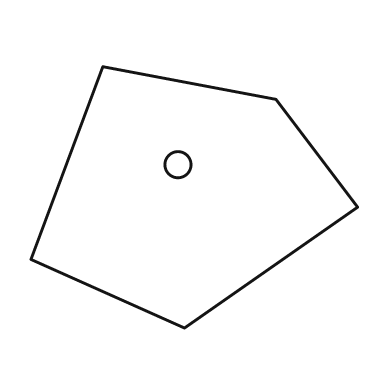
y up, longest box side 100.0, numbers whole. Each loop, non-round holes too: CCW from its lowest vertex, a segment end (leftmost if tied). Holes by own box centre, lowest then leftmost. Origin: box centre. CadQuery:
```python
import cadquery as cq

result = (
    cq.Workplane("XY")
    .moveTo(-3.0, -40.0)
    .lineTo(50.0, -3.0)
    .lineTo(25.0, 30.0)
    .lineTo(-28.0, 40.0)
    .lineTo(-50.0, -19.0)
    .close()
    .moveTo(-5.0, 10.0)
    .circle(4.0)
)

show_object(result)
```